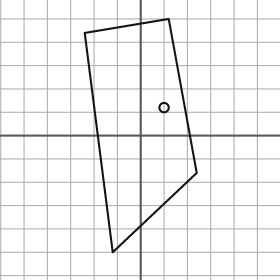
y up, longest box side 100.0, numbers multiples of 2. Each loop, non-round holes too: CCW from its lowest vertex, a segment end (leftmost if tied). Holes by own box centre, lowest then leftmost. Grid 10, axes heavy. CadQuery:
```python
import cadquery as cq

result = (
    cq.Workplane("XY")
    .moveTo(-12.0, -50.0)
    .lineTo(24.0, -16.0)
    .lineTo(12.0, 50.0)
    .lineTo(-24.0, 44.0)
    .close()
    .moveTo(10.0, 12.0)
    .circle(2.0)
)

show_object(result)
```